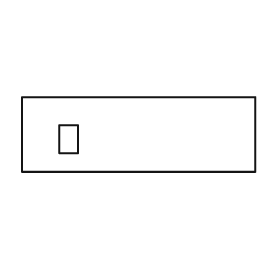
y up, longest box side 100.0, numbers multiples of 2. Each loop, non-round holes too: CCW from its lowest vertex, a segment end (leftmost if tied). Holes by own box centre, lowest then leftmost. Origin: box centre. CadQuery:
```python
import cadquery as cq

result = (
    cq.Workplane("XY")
    .moveTo(-50.0, -16.0)
    .lineTo(50.0, -16.0)
    .lineTo(50.0, 16.0)
    .lineTo(-50.0, 16.0)
    .close()
    .moveTo(-34.0, -8.0)
    .lineTo(-26.0, -8.0)
    .lineTo(-26.0, 4.0)
    .lineTo(-34.0, 4.0)
    .close()
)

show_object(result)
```